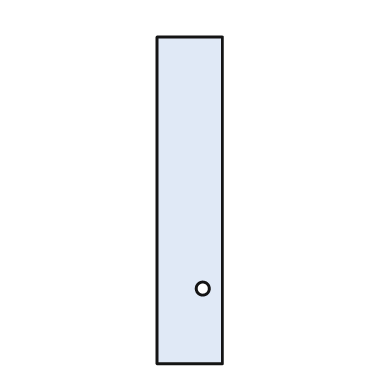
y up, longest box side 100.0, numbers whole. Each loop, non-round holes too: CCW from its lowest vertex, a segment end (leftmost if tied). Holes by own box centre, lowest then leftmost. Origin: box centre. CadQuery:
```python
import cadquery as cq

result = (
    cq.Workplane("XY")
    .moveTo(-10.0, -50.0)
    .lineTo(10.0, -50.0)
    .lineTo(10.0, 50.0)
    .lineTo(-10.0, 50.0)
    .close()
    .moveTo(4.0, -27.0)
    .circle(2.0)
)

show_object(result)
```